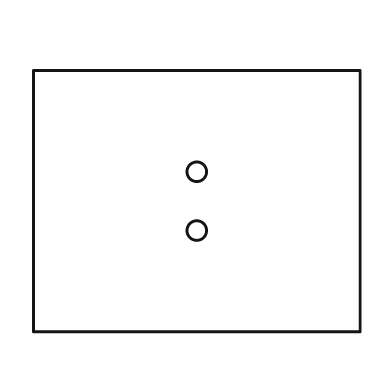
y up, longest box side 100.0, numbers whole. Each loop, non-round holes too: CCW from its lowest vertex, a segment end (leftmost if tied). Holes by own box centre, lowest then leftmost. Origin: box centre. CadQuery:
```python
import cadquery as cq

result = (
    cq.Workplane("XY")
    .moveTo(-50.0, -40.0)
    .lineTo(50.0, -40.0)
    .lineTo(50.0, 40.0)
    .lineTo(-50.0, 40.0)
    .close()
    .moveTo(0.0, -9.0)
    .circle(3.0)
    .moveTo(0.0, 9.0)
    .circle(3.0)
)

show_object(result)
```